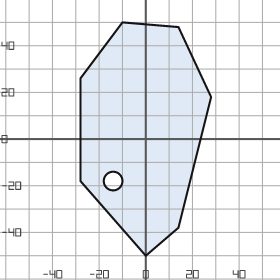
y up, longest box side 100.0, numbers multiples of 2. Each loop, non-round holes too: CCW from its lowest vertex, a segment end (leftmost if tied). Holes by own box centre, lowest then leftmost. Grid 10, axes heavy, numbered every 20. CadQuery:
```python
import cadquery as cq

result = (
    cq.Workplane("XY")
    .moveTo(0.0, -50.0)
    .lineTo(14.0, -38.0)
    .lineTo(28.0, 18.0)
    .lineTo(14.0, 48.0)
    .lineTo(-10.0, 50.0)
    .lineTo(-28.0, 26.0)
    .lineTo(-28.0, -18.0)
    .close()
    .moveTo(-14.0, -18.0)
    .circle(4.0)
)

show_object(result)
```